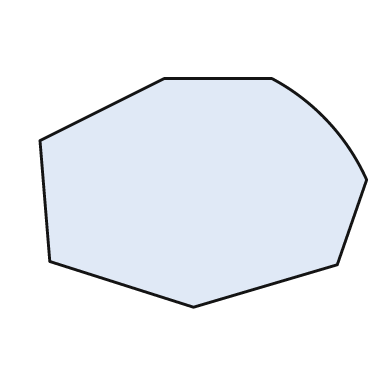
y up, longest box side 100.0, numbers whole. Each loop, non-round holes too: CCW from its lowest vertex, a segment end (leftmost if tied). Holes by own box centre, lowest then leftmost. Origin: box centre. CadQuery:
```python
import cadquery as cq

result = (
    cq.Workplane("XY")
    .moveTo(-3.0, -35.0)
    .lineTo(41.0, -22.0)
    .lineTo(50.0, 4.0)
    .threePointArc((38.0, 22.0), (21.0, 35.0))
    .lineTo(-12.0, 35.0)
    .lineTo(-50.0, 16.0)
    .lineTo(-47.0, -21.0)
    .close()
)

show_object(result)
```